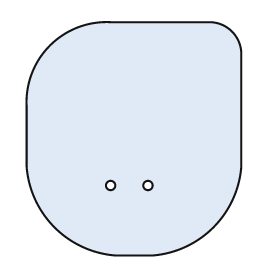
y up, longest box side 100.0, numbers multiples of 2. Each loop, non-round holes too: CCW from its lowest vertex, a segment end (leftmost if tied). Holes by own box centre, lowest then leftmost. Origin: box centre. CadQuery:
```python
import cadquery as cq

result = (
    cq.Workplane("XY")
    .moveTo(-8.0, -50.0)
    .lineTo(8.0, -50.0)
    .threePointArc((34.0, -38.0), (46.0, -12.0))
    .lineTo(46.0, 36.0)
    .threePointArc((42.0, 46.0), (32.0, 50.0))
    .lineTo(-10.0, 50.0)
    .threePointArc((-36.0, 40.0), (-46.0, 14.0))
    .lineTo(-46.0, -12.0)
    .threePointArc((-34.0, -38.0), (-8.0, -50.0))
    .close()
    .moveTo(-10.0, -20.0)
    .circle(2.0)
    .moveTo(6.0, -20.0)
    .circle(2.0)
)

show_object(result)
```